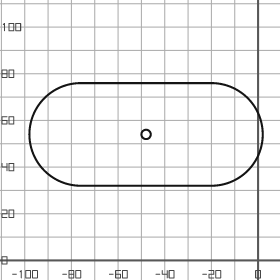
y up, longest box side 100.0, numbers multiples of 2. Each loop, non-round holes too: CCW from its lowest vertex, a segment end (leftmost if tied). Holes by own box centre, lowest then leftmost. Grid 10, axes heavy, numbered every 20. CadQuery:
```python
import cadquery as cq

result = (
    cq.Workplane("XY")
    .moveTo(-76.0, 32.0)
    .lineTo(-20.0, 32.0)
    .threePointArc((2.0, 54.0), (-20.0, 76.0))
    .lineTo(-76.0, 76.0)
    .threePointArc((-98.0, 54.0), (-76.0, 32.0))
    .close()
    .moveTo(-48.0, 54.0)
    .circle(2.0)
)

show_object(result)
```